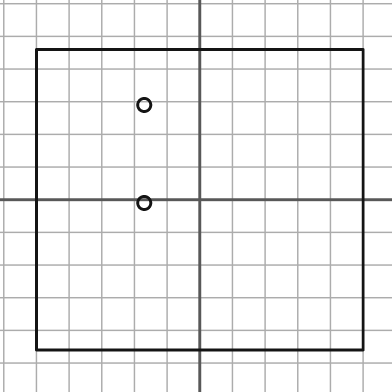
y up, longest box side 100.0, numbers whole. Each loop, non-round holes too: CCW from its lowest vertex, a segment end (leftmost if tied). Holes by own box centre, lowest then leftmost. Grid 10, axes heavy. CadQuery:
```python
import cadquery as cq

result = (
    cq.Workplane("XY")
    .moveTo(-50.0, -46.0)
    .lineTo(50.0, -46.0)
    .lineTo(50.0, 46.0)
    .lineTo(-50.0, 46.0)
    .close()
    .moveTo(-17.0, -1.0)
    .circle(2.0)
    .moveTo(-17.0, 29.0)
    .circle(2.0)
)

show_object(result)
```